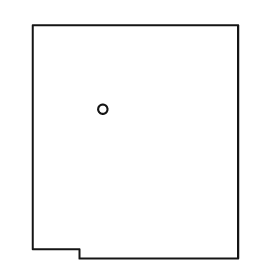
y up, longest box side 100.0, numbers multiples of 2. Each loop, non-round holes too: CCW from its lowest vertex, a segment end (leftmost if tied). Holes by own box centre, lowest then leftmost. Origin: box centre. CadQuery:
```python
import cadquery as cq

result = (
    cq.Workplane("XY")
    .moveTo(-24.0, -50.0)
    .lineTo(44.0, -50.0)
    .lineTo(44.0, 50.0)
    .lineTo(-44.0, 50.0)
    .lineTo(-44.0, -46.0)
    .lineTo(-24.0, -46.0)
    .close()
    .moveTo(-14.0, 14.0)
    .circle(2.0)
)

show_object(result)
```